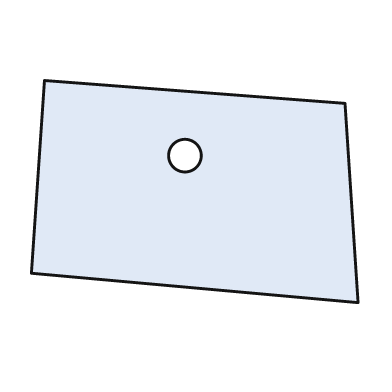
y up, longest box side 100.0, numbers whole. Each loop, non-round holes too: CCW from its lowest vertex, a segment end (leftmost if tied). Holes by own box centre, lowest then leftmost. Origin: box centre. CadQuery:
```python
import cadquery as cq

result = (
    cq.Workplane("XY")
    .moveTo(50.0, -34.0)
    .lineTo(46.0, 27.0)
    .lineTo(-46.0, 34.0)
    .lineTo(-50.0, -25.0)
    .close()
    .moveTo(-3.0, 11.0)
    .circle(5.0)
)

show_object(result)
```